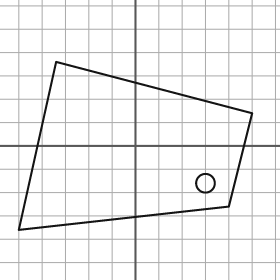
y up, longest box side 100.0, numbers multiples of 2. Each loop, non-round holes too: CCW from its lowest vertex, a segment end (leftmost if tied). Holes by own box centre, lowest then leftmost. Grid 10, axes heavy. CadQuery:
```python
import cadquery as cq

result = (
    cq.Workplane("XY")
    .moveTo(-50.0, -36.0)
    .lineTo(40.0, -26.0)
    .lineTo(50.0, 14.0)
    .lineTo(-34.0, 36.0)
    .close()
    .moveTo(30.0, -16.0)
    .circle(4.0)
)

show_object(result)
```